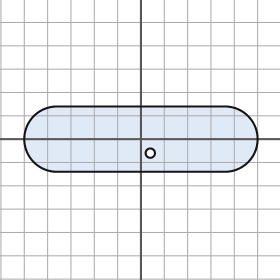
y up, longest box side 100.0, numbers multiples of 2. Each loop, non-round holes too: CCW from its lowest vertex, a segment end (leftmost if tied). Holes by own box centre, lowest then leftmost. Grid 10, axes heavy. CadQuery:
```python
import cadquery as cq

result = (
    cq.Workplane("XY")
    .moveTo(-36.0, -14.0)
    .lineTo(36.0, -14.0)
    .threePointArc((50.0, 0.0), (36.0, 14.0))
    .lineTo(-36.0, 14.0)
    .threePointArc((-50.0, 0.0), (-36.0, -14.0))
    .close()
    .moveTo(4.0, -6.0)
    .circle(2.0)
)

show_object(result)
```